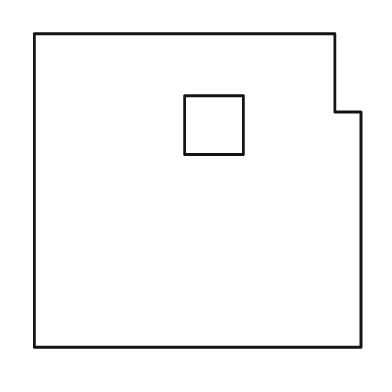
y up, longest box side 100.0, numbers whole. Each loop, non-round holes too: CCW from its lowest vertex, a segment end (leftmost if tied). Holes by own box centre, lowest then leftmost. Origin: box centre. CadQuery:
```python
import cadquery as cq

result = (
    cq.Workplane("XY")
    .moveTo(-50.0, -48.0)
    .lineTo(50.0, -48.0)
    .lineTo(50.0, 24.0)
    .lineTo(42.0, 24.0)
    .lineTo(42.0, 48.0)
    .lineTo(-50.0, 48.0)
    .close()
    .moveTo(-4.0, 11.0)
    .lineTo(14.0, 11.0)
    .lineTo(14.0, 29.0)
    .lineTo(-4.0, 29.0)
    .close()
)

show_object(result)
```